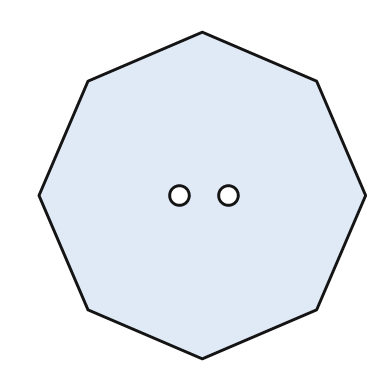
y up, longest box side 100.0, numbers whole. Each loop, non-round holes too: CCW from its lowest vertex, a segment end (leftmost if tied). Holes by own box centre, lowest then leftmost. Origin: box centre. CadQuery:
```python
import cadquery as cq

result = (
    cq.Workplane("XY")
    .moveTo(0.0, -50.0)
    .lineTo(35.0, -35.0)
    .lineTo(50.0, 0.0)
    .lineTo(35.0, 35.0)
    .lineTo(0.0, 50.0)
    .lineTo(-35.0, 35.0)
    .lineTo(-50.0, 0.0)
    .lineTo(-35.0, -35.0)
    .close()
    .moveTo(-7.0, 0.0)
    .circle(3.0)
    .moveTo(8.0, 0.0)
    .circle(3.0)
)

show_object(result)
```